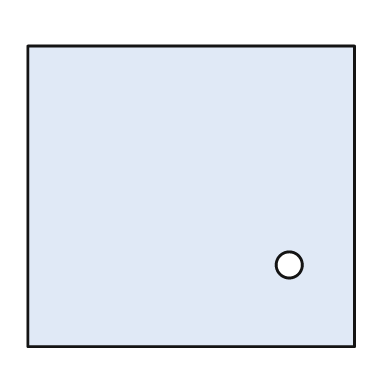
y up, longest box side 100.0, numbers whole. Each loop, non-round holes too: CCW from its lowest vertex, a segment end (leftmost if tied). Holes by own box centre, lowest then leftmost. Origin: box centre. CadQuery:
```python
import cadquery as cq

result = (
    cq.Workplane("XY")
    .moveTo(-50.0, -46.0)
    .lineTo(50.0, -46.0)
    .lineTo(50.0, 46.0)
    .lineTo(-50.0, 46.0)
    .close()
    .moveTo(30.0, -21.0)
    .circle(4.0)
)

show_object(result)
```